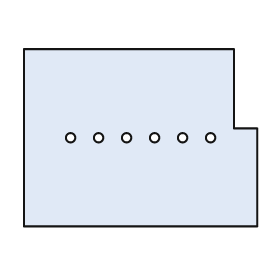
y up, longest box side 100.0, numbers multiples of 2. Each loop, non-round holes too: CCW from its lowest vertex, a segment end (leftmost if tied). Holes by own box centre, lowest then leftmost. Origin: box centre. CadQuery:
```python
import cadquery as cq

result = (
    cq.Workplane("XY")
    .moveTo(-50.0, -38.0)
    .lineTo(50.0, -38.0)
    .lineTo(50.0, 4.0)
    .lineTo(40.0, 4.0)
    .lineTo(40.0, 38.0)
    .lineTo(-50.0, 38.0)
    .close()
    .moveTo(-30.0, 0.0)
    .circle(2.0)
    .moveTo(-18.0, 0.0)
    .circle(2.0)
    .moveTo(-6.0, 0.0)
    .circle(2.0)
    .moveTo(6.0, 0.0)
    .circle(2.0)
    .moveTo(18.0, 0.0)
    .circle(2.0)
    .moveTo(30.0, 0.0)
    .circle(2.0)
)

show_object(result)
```